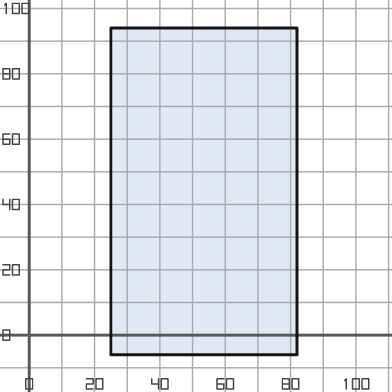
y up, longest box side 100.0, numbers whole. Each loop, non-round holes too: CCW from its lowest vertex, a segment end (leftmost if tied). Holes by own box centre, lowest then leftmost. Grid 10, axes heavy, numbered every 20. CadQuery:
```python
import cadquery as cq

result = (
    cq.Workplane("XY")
    .moveTo(25.0, -6.0)
    .lineTo(82.0, -6.0)
    .lineTo(82.0, 94.0)
    .lineTo(25.0, 94.0)
    .close()
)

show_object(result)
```